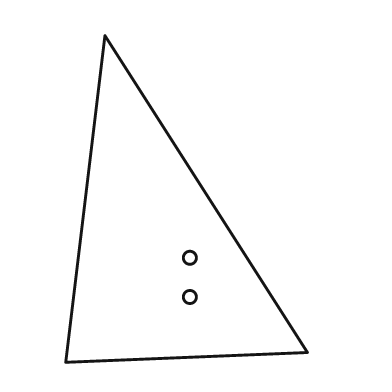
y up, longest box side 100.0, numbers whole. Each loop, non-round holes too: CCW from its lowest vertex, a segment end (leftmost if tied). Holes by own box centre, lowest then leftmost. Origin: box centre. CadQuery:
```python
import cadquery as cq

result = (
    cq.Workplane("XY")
    .moveTo(-37.0, -50.0)
    .lineTo(37.0, -47.0)
    .lineTo(-25.0, 50.0)
    .close()
    .moveTo(1.0, -30.0)
    .circle(2.0)
    .moveTo(1.0, -18.0)
    .circle(2.0)
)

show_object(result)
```